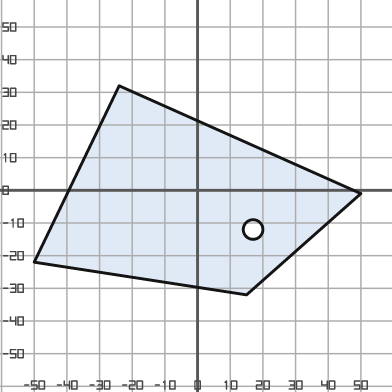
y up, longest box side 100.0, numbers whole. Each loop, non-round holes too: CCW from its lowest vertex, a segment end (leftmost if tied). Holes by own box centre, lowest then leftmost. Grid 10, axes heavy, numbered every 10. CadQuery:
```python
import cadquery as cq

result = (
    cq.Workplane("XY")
    .moveTo(15.0, -32.0)
    .lineTo(50.0, -1.0)
    .lineTo(-24.0, 32.0)
    .lineTo(-50.0, -22.0)
    .close()
    .moveTo(17.0, -12.0)
    .circle(3.0)
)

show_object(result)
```